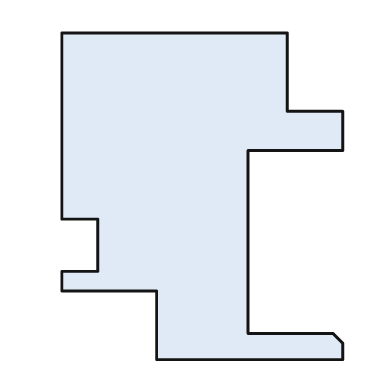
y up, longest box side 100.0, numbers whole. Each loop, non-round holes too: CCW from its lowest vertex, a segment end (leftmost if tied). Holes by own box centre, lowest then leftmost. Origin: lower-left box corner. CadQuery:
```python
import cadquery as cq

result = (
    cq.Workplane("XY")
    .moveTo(29.0, 0.0)
    .lineTo(86.0, 0.0)
    .lineTo(86.0, 5.0)
    .lineTo(83.0, 8.0)
    .lineTo(57.0, 8.0)
    .lineTo(57.0, 64.0)
    .lineTo(86.0, 64.0)
    .lineTo(86.0, 76.0)
    .lineTo(69.0, 76.0)
    .lineTo(69.0, 100.0)
    .lineTo(0.0, 100.0)
    .lineTo(0.0, 43.0)
    .lineTo(11.0, 43.0)
    .lineTo(11.0, 27.0)
    .lineTo(0.0, 27.0)
    .lineTo(0.0, 21.0)
    .lineTo(29.0, 21.0)
    .close()
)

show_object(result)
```